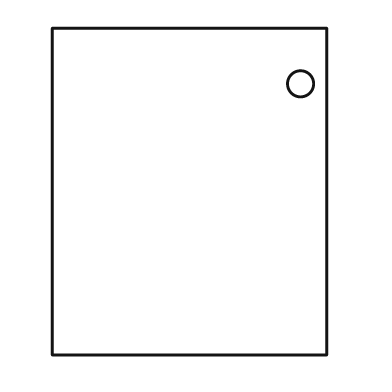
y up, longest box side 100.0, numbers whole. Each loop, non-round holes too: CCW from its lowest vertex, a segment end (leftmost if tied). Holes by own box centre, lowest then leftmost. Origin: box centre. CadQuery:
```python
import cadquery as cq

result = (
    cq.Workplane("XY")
    .moveTo(-42.0, -50.0)
    .lineTo(42.0, -50.0)
    .lineTo(42.0, 50.0)
    .lineTo(-42.0, 50.0)
    .close()
    .moveTo(34.0, 33.0)
    .circle(4.0)
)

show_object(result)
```